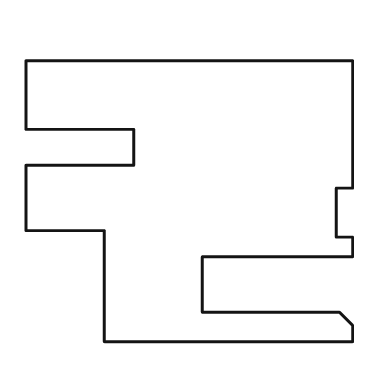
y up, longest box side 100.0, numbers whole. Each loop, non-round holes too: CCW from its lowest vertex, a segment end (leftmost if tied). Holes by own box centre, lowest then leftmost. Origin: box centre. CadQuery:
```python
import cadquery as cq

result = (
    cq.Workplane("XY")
    .moveTo(-26.0, -43.0)
    .lineTo(50.0, -43.0)
    .lineTo(50.0, -38.0)
    .lineTo(46.0, -34.0)
    .lineTo(4.0, -34.0)
    .lineTo(4.0, -17.0)
    .lineTo(50.0, -17.0)
    .lineTo(50.0, -11.0)
    .lineTo(45.0, -11.0)
    .lineTo(45.0, 4.0)
    .lineTo(50.0, 4.0)
    .lineTo(50.0, 43.0)
    .lineTo(-50.0, 43.0)
    .lineTo(-50.0, 22.0)
    .lineTo(-17.0, 22.0)
    .lineTo(-17.0, 11.0)
    .lineTo(-50.0, 11.0)
    .lineTo(-50.0, -9.0)
    .lineTo(-26.0, -9.0)
    .close()
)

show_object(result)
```